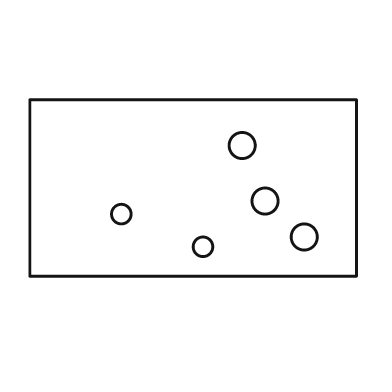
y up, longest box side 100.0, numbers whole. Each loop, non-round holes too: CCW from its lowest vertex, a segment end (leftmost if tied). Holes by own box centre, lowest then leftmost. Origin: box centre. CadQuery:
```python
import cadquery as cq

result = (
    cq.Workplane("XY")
    .moveTo(-50.0, -27.0)
    .lineTo(50.0, -27.0)
    .lineTo(50.0, 27.0)
    .lineTo(-50.0, 27.0)
    .close()
    .moveTo(3.0, -18.0)
    .circle(3.0)
    .moveTo(34.0, -15.0)
    .circle(4.0)
    .moveTo(-22.0, -8.0)
    .circle(3.0)
    .moveTo(22.0, -4.0)
    .circle(4.0)
    .moveTo(15.0, 13.0)
    .circle(4.0)
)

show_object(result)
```